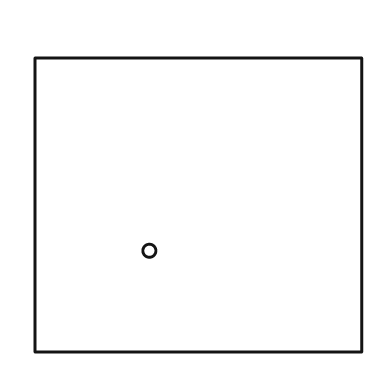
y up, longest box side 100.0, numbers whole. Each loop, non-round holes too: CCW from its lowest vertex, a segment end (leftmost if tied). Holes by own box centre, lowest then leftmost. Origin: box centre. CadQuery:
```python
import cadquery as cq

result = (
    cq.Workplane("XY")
    .moveTo(-50.0, -45.0)
    .lineTo(50.0, -45.0)
    .lineTo(50.0, 45.0)
    .lineTo(-50.0, 45.0)
    .close()
    .moveTo(-15.0, -14.0)
    .circle(2.0)
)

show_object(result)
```